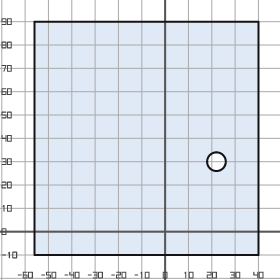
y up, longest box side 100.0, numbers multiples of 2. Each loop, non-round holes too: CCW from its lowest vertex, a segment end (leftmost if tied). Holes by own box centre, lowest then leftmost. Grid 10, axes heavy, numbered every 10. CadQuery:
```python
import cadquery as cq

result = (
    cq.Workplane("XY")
    .moveTo(-56.0, -10.0)
    .lineTo(40.0, -10.0)
    .lineTo(40.0, 90.0)
    .lineTo(-56.0, 90.0)
    .close()
    .moveTo(22.0, 30.0)
    .circle(4.0)
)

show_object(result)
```